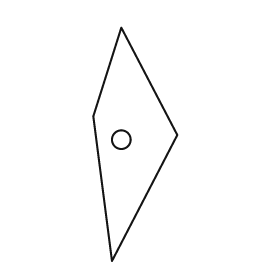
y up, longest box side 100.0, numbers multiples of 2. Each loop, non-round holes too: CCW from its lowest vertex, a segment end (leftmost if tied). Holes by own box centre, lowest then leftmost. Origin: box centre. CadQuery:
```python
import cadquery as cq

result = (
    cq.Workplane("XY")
    .moveTo(-10.0, -50.0)
    .lineTo(18.0, 4.0)
    .lineTo(-6.0, 50.0)
    .lineTo(-18.0, 12.0)
    .close()
    .moveTo(-6.0, 2.0)
    .circle(4.0)
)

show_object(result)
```